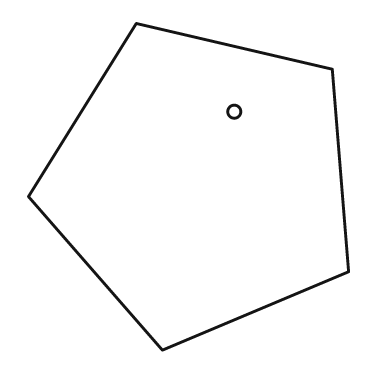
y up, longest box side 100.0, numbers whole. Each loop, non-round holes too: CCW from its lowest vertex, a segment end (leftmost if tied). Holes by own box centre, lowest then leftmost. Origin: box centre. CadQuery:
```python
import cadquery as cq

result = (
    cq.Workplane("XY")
    .moveTo(-8.0, -50.0)
    .lineTo(49.0, -26.0)
    .lineTo(44.0, 36.0)
    .lineTo(-16.0, 50.0)
    .lineTo(-49.0, -3.0)
    .close()
    .moveTo(14.0, 23.0)
    .circle(2.0)
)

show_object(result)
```